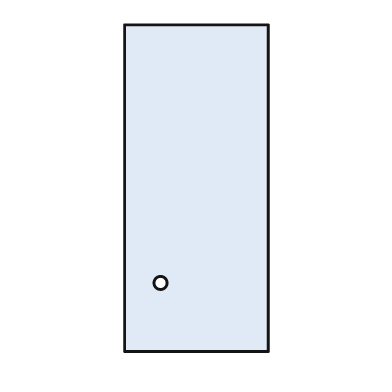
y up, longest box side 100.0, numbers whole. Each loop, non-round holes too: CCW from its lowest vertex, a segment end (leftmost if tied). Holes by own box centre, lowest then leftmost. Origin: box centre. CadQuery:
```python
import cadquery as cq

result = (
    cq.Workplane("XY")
    .moveTo(-22.0, -50.0)
    .lineTo(22.0, -50.0)
    .lineTo(22.0, 50.0)
    .lineTo(-22.0, 50.0)
    .close()
    .moveTo(-11.0, -29.0)
    .circle(2.0)
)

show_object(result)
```